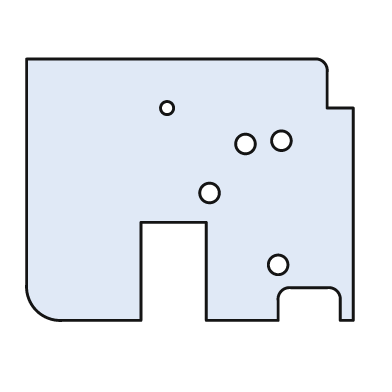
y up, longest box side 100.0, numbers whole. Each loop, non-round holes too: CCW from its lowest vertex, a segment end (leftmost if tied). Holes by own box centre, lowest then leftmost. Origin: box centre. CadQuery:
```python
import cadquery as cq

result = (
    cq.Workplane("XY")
    .moveTo(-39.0, -40.0)
    .lineTo(-15.0, -40.0)
    .lineTo(-15.0, -10.0)
    .lineTo(5.0, -10.0)
    .lineTo(5.0, -40.0)
    .lineTo(27.0, -40.0)
    .lineTo(27.0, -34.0)
    .threePointArc((28.0, -31.0), (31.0, -30.0))
    .lineTo(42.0, -30.0)
    .threePointArc((45.0, -31.0), (46.0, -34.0))
    .lineTo(46.0, -40.0)
    .lineTo(50.0, -40.0)
    .lineTo(50.0, 25.0)
    .lineTo(42.0, 25.0)
    .lineTo(42.0, 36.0)
    .threePointArc((41.0, 39.0), (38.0, 40.0))
    .lineTo(-50.0, 40.0)
    .lineTo(-50.0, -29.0)
    .threePointArc((-47.0, -37.0), (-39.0, -40.0))
    .close()
    .moveTo(27.0, -23.0)
    .circle(3.0)
    .moveTo(6.0, -1.0)
    .circle(3.0)
    .moveTo(17.0, 14.0)
    .circle(3.0)
    .moveTo(28.0, 15.0)
    .circle(3.0)
    .moveTo(-7.0, 25.0)
    .circle(2.0)
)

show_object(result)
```